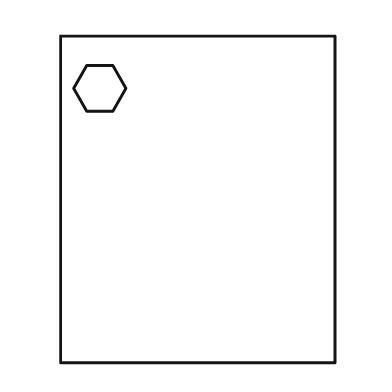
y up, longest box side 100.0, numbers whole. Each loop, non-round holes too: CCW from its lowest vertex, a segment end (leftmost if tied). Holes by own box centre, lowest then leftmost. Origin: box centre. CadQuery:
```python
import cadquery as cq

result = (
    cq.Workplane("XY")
    .moveTo(-42.0, -50.0)
    .lineTo(42.0, -50.0)
    .lineTo(42.0, 50.0)
    .lineTo(-42.0, 50.0)
    .close()
    .moveTo(-34.0, 27.0)
    .lineTo(-26.0, 27.0)
    .lineTo(-22.0, 34.0)
    .lineTo(-26.0, 41.0)
    .lineTo(-34.0, 41.0)
    .lineTo(-38.0, 34.0)
    .close()
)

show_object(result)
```